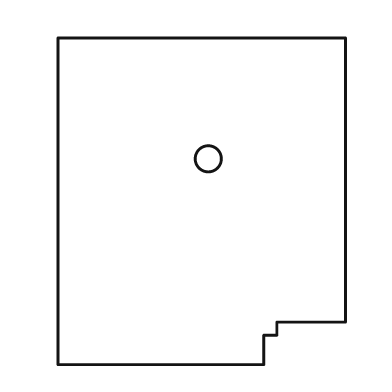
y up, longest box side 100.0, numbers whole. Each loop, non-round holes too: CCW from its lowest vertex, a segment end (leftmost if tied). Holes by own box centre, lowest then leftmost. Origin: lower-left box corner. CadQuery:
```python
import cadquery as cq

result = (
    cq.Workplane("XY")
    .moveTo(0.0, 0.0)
    .lineTo(63.0, 0.0)
    .lineTo(63.0, 9.0)
    .lineTo(67.0, 9.0)
    .lineTo(67.0, 13.0)
    .lineTo(88.0, 13.0)
    .lineTo(88.0, 100.0)
    .lineTo(0.0, 100.0)
    .close()
    .moveTo(46.0, 63.0)
    .circle(4.0)
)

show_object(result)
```